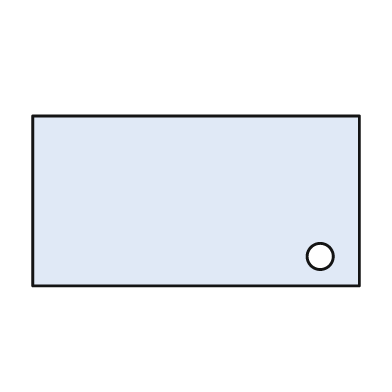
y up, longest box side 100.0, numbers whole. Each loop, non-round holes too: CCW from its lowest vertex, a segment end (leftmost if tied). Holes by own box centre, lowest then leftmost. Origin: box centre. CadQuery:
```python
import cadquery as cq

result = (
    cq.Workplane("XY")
    .moveTo(-50.0, -26.0)
    .lineTo(50.0, -26.0)
    .lineTo(50.0, 26.0)
    .lineTo(-50.0, 26.0)
    .close()
    .moveTo(38.0, -17.0)
    .circle(4.0)
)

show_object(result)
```